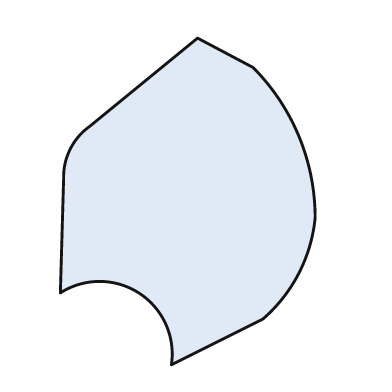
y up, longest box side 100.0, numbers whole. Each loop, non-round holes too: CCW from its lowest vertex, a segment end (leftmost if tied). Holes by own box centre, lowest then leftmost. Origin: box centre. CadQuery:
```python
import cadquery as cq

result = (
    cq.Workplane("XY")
    .moveTo(-5.0, -50.0)
    .lineTo(23.0, -36.0)
    .threePointArc((34.0, -22.0), (39.0, -5.0))
    .threePointArc((34.0, 20.0), (20.0, 41.0))
    .lineTo(3.0, 50.0)
    .lineTo(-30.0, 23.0)
    .threePointArc((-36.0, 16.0), (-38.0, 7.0))
    .lineTo(-39.0, -28.0)
    .threePointArc((-15.0, -28.0), (-5.0, -50.0))
    .close()
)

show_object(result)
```